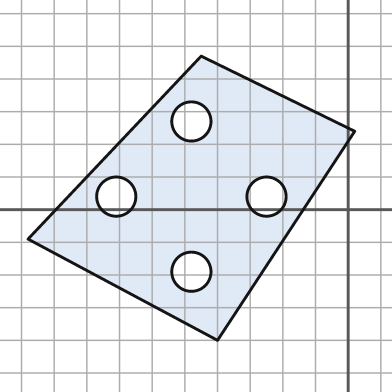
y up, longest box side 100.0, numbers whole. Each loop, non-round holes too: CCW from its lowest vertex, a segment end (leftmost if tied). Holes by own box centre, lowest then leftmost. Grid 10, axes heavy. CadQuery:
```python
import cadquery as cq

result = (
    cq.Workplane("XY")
    .moveTo(-40.0, -40.0)
    .lineTo(2.0, 24.0)
    .lineTo(-45.0, 47.0)
    .lineTo(-98.0, -9.0)
    .close()
    .moveTo(-48.0, -19.0)
    .circle(6.0)
    .moveTo(-71.0, 4.0)
    .circle(6.0)
    .moveTo(-25.0, 4.0)
    .circle(6.0)
    .moveTo(-48.0, 27.0)
    .circle(6.0)
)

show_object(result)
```